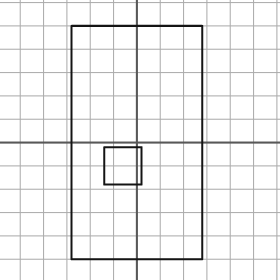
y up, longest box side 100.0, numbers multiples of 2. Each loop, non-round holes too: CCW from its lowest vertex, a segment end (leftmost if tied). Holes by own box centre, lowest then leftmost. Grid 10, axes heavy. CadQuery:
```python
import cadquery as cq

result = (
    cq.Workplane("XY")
    .moveTo(-28.0, -50.0)
    .lineTo(28.0, -50.0)
    .lineTo(28.0, 50.0)
    .lineTo(-28.0, 50.0)
    .close()
    .moveTo(-14.0, -18.0)
    .lineTo(2.0, -18.0)
    .lineTo(2.0, -2.0)
    .lineTo(-14.0, -2.0)
    .close()
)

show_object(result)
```